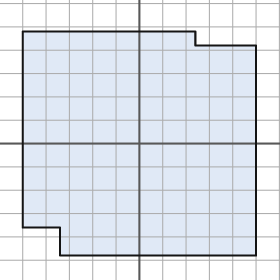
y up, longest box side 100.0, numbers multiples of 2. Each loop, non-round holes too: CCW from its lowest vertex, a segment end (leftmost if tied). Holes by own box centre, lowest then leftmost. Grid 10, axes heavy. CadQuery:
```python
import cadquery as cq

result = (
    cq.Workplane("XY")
    .moveTo(-34.0, -48.0)
    .lineTo(50.0, -48.0)
    .lineTo(50.0, 42.0)
    .lineTo(24.0, 42.0)
    .lineTo(24.0, 48.0)
    .lineTo(-50.0, 48.0)
    .lineTo(-50.0, -36.0)
    .lineTo(-34.0, -36.0)
    .close()
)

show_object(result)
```